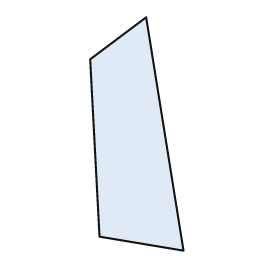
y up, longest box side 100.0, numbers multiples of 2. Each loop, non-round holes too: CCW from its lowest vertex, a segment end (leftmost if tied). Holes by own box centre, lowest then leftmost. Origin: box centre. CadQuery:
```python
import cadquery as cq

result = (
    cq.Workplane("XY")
    .moveTo(20.0, -50.0)
    .lineTo(4.0, 50.0)
    .lineTo(-20.0, 32.0)
    .lineTo(-16.0, -44.0)
    .close()
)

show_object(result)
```